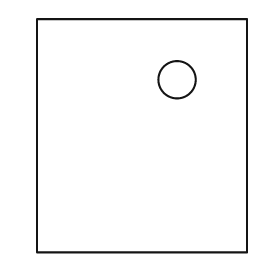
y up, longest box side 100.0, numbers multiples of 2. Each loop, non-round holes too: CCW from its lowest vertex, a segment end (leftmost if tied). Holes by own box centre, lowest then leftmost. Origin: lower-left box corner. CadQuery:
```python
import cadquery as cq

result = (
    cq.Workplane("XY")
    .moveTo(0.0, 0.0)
    .lineTo(90.0, 0.0)
    .lineTo(90.0, 100.0)
    .lineTo(0.0, 100.0)
    .close()
    .moveTo(60.0, 74.0)
    .circle(8.0)
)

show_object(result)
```